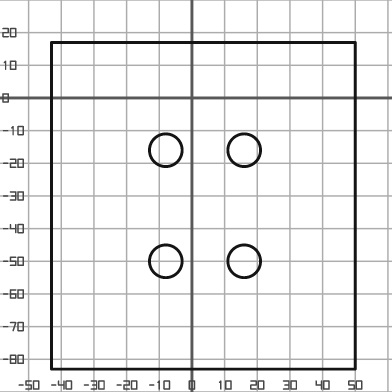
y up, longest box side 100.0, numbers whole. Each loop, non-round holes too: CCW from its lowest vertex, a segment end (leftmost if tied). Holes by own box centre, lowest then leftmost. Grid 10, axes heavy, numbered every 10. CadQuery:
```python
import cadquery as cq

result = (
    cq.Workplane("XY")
    .moveTo(-43.0, -83.0)
    .lineTo(50.0, -83.0)
    .lineTo(50.0, 17.0)
    .lineTo(-43.0, 17.0)
    .close()
    .moveTo(-8.0, -50.0)
    .circle(5.0)
    .moveTo(16.0, -50.0)
    .circle(5.0)
    .moveTo(-8.0, -16.0)
    .circle(5.0)
    .moveTo(16.0, -16.0)
    .circle(5.0)
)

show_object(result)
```